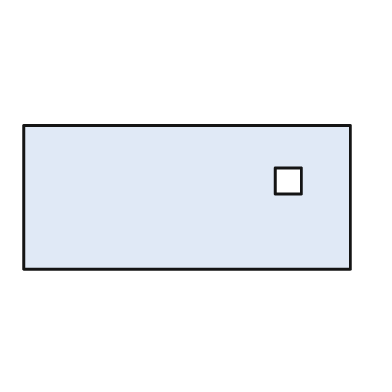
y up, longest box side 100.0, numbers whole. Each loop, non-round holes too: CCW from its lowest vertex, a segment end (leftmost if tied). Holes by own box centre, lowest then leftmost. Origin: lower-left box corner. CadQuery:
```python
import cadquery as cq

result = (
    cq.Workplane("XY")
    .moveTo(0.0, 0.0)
    .lineTo(100.0, 0.0)
    .lineTo(100.0, 44.0)
    .lineTo(0.0, 44.0)
    .close()
    .moveTo(77.0, 23.0)
    .lineTo(85.0, 23.0)
    .lineTo(85.0, 31.0)
    .lineTo(77.0, 31.0)
    .close()
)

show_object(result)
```